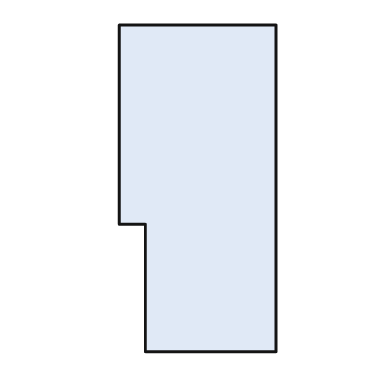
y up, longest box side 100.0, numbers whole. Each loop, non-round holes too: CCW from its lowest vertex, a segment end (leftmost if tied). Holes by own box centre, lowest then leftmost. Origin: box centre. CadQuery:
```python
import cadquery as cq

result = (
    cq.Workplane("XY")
    .moveTo(-16.0, -50.0)
    .lineTo(24.0, -50.0)
    .lineTo(24.0, 50.0)
    .lineTo(-24.0, 50.0)
    .lineTo(-24.0, -11.0)
    .lineTo(-16.0, -11.0)
    .close()
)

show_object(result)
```